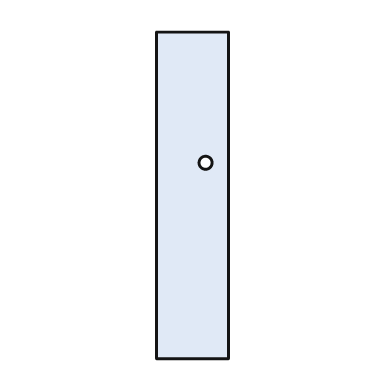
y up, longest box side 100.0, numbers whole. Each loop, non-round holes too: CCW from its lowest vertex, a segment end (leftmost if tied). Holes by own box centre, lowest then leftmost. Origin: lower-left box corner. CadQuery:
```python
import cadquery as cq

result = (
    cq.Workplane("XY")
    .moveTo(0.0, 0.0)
    .lineTo(22.0, 0.0)
    .lineTo(22.0, 100.0)
    .lineTo(0.0, 100.0)
    .close()
    .moveTo(15.0, 60.0)
    .circle(2.0)
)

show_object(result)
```